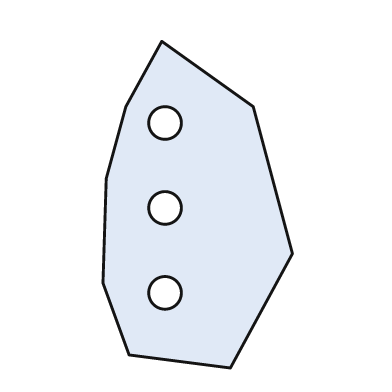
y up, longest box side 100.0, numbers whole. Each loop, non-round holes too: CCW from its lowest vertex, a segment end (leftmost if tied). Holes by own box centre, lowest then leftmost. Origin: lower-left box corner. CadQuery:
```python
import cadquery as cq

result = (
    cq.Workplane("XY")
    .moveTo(39.0, 0.0)
    .lineTo(58.0, 35.0)
    .lineTo(46.0, 80.0)
    .lineTo(18.0, 100.0)
    .lineTo(7.0, 80.0)
    .lineTo(1.0, 58.0)
    .lineTo(0.0, 26.0)
    .lineTo(8.0, 4.0)
    .close()
    .moveTo(19.0, 23.0)
    .circle(5.0)
    .moveTo(19.0, 49.0)
    .circle(5.0)
    .moveTo(19.0, 75.0)
    .circle(5.0)
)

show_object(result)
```